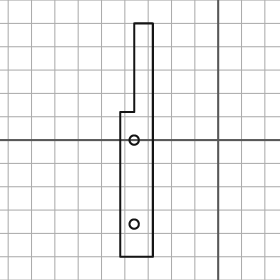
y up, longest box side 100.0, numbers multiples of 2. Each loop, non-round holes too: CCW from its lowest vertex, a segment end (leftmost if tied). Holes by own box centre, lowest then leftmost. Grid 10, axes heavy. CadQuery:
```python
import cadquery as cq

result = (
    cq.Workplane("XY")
    .moveTo(-42.0, -50.0)
    .lineTo(-28.0, -50.0)
    .lineTo(-28.0, 50.0)
    .lineTo(-36.0, 50.0)
    .lineTo(-36.0, 12.0)
    .lineTo(-42.0, 12.0)
    .close()
    .moveTo(-36.0, -36.0)
    .circle(2.0)
    .moveTo(-36.0, 0.0)
    .circle(2.0)
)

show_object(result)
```